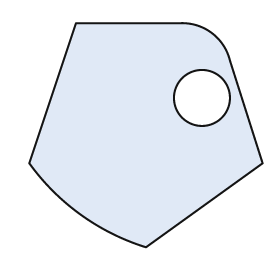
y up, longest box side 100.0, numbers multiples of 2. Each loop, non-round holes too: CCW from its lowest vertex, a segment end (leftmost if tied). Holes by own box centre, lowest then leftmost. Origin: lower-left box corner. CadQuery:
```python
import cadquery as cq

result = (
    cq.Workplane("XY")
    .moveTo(50.0, 0.0)
    .lineTo(100.0, 36.0)
    .lineTo(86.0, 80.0)
    .threePointArc((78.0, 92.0), (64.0, 96.0))
    .lineTo(20.0, 96.0)
    .lineTo(0.0, 36.0)
    .threePointArc((22.0, 14.0), (50.0, 0.0))
    .close()
    .moveTo(74.0, 64.0)
    .circle(12.0)
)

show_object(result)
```